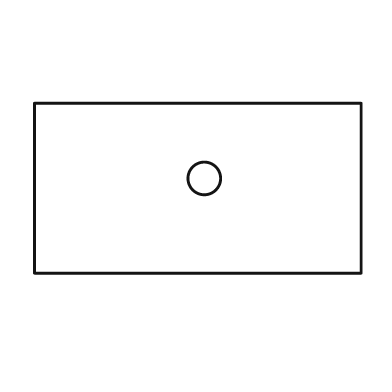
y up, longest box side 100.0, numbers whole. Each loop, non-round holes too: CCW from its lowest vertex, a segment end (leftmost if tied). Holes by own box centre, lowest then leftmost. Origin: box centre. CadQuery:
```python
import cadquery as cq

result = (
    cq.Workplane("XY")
    .moveTo(-50.0, -26.0)
    .lineTo(50.0, -26.0)
    .lineTo(50.0, 26.0)
    .lineTo(-50.0, 26.0)
    .close()
    .moveTo(2.0, 3.0)
    .circle(5.0)
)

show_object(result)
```